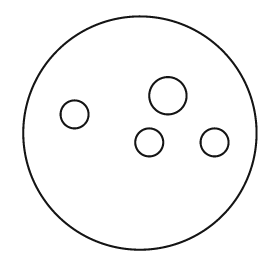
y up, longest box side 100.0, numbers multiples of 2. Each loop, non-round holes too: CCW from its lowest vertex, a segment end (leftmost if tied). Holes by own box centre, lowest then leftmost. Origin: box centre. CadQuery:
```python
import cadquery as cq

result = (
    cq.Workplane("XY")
    .moveTo(0.0, 0.0)
    .circle(50.0)
    .moveTo(4.0, -4.0)
    .circle(6.0)
    .moveTo(32.0, -4.0)
    .circle(6.0)
    .moveTo(-28.0, 8.0)
    .circle(6.0)
    .moveTo(12.0, 16.0)
    .circle(8.0)
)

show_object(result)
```